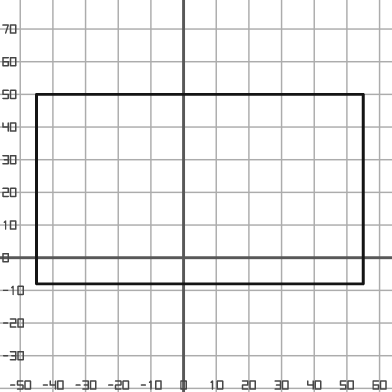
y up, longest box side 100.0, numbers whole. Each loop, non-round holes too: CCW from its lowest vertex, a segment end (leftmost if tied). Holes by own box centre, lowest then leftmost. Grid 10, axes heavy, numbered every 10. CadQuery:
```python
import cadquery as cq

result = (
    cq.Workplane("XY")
    .moveTo(-45.0, -8.0)
    .lineTo(55.0, -8.0)
    .lineTo(55.0, 50.0)
    .lineTo(-45.0, 50.0)
    .close()
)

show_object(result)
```